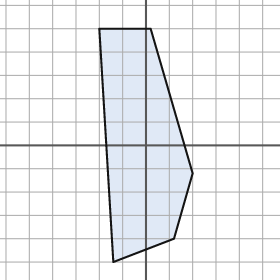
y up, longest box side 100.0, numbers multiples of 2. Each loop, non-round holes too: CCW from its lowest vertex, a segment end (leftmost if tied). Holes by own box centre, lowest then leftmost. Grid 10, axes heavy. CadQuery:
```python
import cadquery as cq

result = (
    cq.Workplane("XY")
    .moveTo(-14.0, -50.0)
    .lineTo(12.0, -40.0)
    .lineTo(20.0, -12.0)
    .lineTo(2.0, 50.0)
    .lineTo(-20.0, 50.0)
    .close()
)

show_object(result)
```